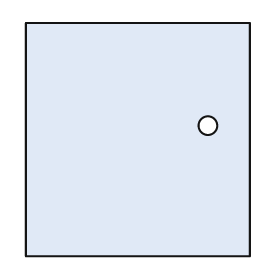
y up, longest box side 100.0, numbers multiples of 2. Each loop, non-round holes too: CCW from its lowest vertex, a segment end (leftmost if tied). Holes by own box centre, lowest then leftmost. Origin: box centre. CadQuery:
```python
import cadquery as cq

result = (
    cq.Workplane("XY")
    .moveTo(-48.0, -50.0)
    .lineTo(48.0, -50.0)
    .lineTo(48.0, 50.0)
    .lineTo(-48.0, 50.0)
    .close()
    .moveTo(30.0, 6.0)
    .circle(4.0)
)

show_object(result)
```